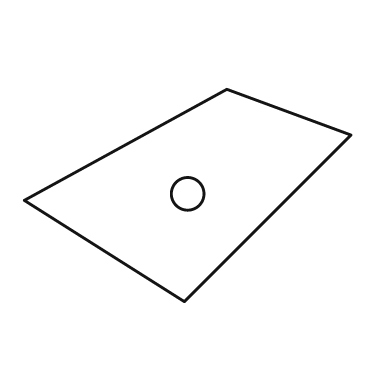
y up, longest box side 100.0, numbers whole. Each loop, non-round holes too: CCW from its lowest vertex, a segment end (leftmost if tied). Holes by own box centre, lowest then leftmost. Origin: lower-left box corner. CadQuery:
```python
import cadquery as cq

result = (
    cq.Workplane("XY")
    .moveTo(49.0, 0.0)
    .lineTo(100.0, 51.0)
    .lineTo(62.0, 65.0)
    .lineTo(0.0, 31.0)
    .close()
    .moveTo(50.0, 33.0)
    .circle(5.0)
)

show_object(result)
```